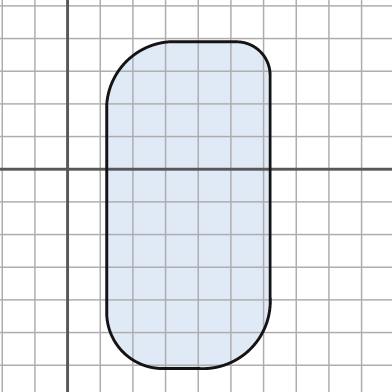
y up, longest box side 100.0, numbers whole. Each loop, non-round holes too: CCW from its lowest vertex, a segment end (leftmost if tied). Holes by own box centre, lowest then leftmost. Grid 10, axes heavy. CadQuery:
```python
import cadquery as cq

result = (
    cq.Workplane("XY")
    .moveTo(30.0, -61.0)
    .lineTo(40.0, -61.0)
    .threePointArc((56.0, -55.0), (62.0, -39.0))
    .lineTo(62.0, 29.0)
    .threePointArc((59.0, 36.0), (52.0, 39.0))
    .lineTo(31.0, 39.0)
    .threePointArc((18.0, 33.0), (12.0, 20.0))
    .lineTo(12.0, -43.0)
    .threePointArc((17.0, -56.0), (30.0, -61.0))
    .close()
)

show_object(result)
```